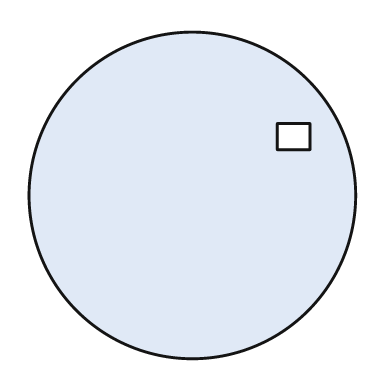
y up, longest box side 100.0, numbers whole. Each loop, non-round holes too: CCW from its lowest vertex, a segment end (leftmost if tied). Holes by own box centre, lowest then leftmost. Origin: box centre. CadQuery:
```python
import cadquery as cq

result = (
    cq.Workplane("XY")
    .moveTo(0.0, 0.0)
    .circle(50.0)
    .moveTo(26.0, 14.0)
    .lineTo(36.0, 14.0)
    .lineTo(36.0, 22.0)
    .lineTo(26.0, 22.0)
    .close()
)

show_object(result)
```